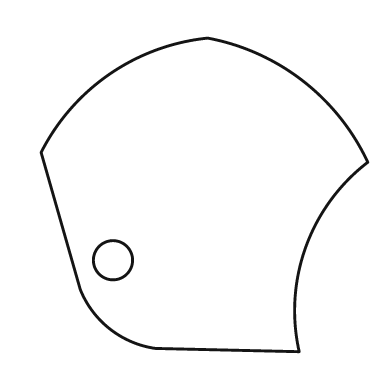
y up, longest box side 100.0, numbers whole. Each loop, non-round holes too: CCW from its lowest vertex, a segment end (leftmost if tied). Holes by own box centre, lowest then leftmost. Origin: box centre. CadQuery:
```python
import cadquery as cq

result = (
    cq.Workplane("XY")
    .moveTo(29.0, -48.0)
    .threePointArc((31.0, -16.0), (50.0, 10.0))
    .threePointArc((30.0, 35.0), (1.0, 48.0))
    .threePointArc((-29.0, 37.0), (-50.0, 13.0))
    .lineTo(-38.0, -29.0)
    .threePointArc((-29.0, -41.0), (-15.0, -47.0))
    .close()
    .moveTo(-28.0, -20.0)
    .circle(6.0)
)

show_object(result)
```